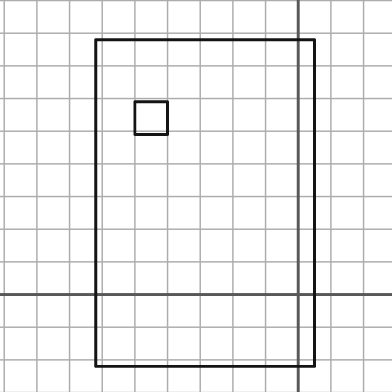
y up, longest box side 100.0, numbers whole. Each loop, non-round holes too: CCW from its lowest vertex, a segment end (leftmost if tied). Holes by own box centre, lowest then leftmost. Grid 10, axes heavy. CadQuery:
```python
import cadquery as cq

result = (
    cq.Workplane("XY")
    .moveTo(-62.0, -22.0)
    .lineTo(5.0, -22.0)
    .lineTo(5.0, 78.0)
    .lineTo(-62.0, 78.0)
    .close()
    .moveTo(-50.0, 49.0)
    .lineTo(-40.0, 49.0)
    .lineTo(-40.0, 59.0)
    .lineTo(-50.0, 59.0)
    .close()
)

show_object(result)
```